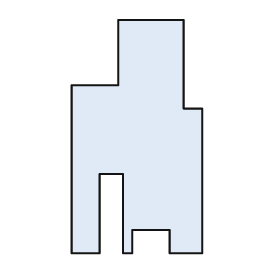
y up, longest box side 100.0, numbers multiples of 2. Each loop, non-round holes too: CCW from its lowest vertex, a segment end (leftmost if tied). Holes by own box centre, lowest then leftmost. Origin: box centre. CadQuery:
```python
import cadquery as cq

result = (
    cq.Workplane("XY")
    .moveTo(-28.0, -50.0)
    .lineTo(-16.0, -50.0)
    .lineTo(-16.0, -16.0)
    .lineTo(-6.0, -16.0)
    .lineTo(-6.0, -50.0)
    .lineTo(-2.0, -50.0)
    .lineTo(-2.0, -40.0)
    .lineTo(14.0, -40.0)
    .lineTo(14.0, -50.0)
    .lineTo(28.0, -50.0)
    .lineTo(28.0, 12.0)
    .lineTo(20.0, 12.0)
    .lineTo(20.0, 50.0)
    .lineTo(-8.0, 50.0)
    .lineTo(-8.0, 22.0)
    .lineTo(-28.0, 22.0)
    .close()
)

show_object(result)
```